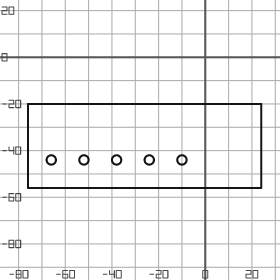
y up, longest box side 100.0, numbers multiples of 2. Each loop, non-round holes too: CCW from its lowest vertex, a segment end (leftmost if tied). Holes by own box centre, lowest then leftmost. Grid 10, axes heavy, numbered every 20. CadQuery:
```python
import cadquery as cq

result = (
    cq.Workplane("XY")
    .moveTo(-76.0, -56.0)
    .lineTo(24.0, -56.0)
    .lineTo(24.0, -20.0)
    .lineTo(-76.0, -20.0)
    .close()
    .moveTo(-66.0, -44.0)
    .circle(2.0)
    .moveTo(-52.0, -44.0)
    .circle(2.0)
    .moveTo(-38.0, -44.0)
    .circle(2.0)
    .moveTo(-24.0, -44.0)
    .circle(2.0)
    .moveTo(-10.0, -44.0)
    .circle(2.0)
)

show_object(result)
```